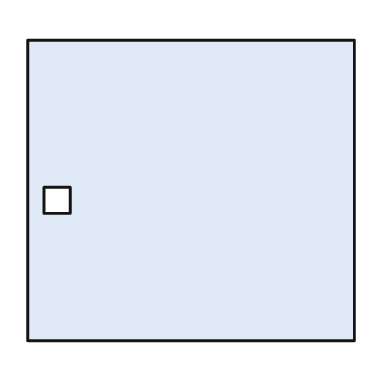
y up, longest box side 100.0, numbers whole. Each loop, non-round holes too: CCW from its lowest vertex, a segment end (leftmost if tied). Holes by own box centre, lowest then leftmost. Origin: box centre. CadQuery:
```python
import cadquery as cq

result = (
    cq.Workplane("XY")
    .moveTo(-50.0, -46.0)
    .lineTo(50.0, -46.0)
    .lineTo(50.0, 46.0)
    .lineTo(-50.0, 46.0)
    .close()
    .moveTo(-45.0, -7.0)
    .lineTo(-37.0, -7.0)
    .lineTo(-37.0, 1.0)
    .lineTo(-45.0, 1.0)
    .close()
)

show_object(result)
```